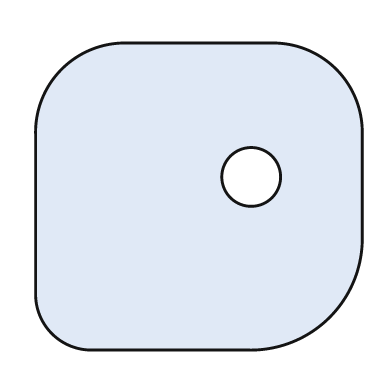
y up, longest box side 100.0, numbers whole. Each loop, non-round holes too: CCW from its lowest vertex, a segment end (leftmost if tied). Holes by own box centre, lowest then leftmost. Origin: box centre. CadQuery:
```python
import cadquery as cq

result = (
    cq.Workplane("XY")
    .moveTo(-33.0, -47.0)
    .lineTo(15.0, -47.0)
    .threePointArc((40.0, -37.0), (50.0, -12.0))
    .lineTo(50.0, 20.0)
    .threePointArc((42.0, 39.0), (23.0, 47.0))
    .lineTo(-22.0, 47.0)
    .threePointArc((-42.0, 39.0), (-50.0, 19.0))
    .lineTo(-50.0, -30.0)
    .threePointArc((-45.0, -42.0), (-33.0, -47.0))
    .close()
    .moveTo(16.0, 6.0)
    .circle(9.0)
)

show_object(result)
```